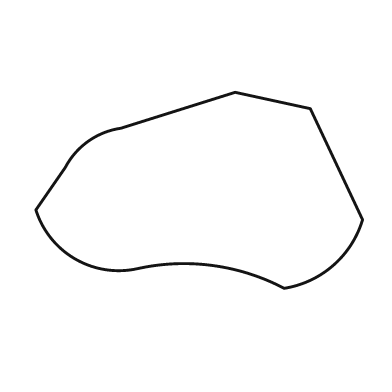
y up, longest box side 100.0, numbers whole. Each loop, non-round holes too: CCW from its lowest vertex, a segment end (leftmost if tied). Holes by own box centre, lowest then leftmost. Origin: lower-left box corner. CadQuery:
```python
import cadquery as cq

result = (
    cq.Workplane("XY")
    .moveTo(76.0, 0.0)
    .threePointArc((91.0, 7.0), (100.0, 21.0))
    .lineTo(84.0, 55.0)
    .lineTo(61.0, 60.0)
    .lineTo(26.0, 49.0)
    .threePointArc((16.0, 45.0), (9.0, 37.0))
    .lineTo(0.0, 24.0)
    .threePointArc((12.0, 9.0), (31.0, 6.0))
    .threePointArc((54.0, 7.0), (76.0, 0.0))
    .close()
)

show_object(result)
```